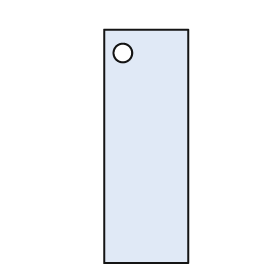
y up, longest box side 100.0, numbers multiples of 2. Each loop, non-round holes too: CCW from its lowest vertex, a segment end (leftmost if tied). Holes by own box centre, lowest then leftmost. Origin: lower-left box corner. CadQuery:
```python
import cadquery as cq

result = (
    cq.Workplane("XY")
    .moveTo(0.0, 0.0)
    .lineTo(36.0, 0.0)
    .lineTo(36.0, 100.0)
    .lineTo(0.0, 100.0)
    .close()
    .moveTo(8.0, 90.0)
    .circle(4.0)
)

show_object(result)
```